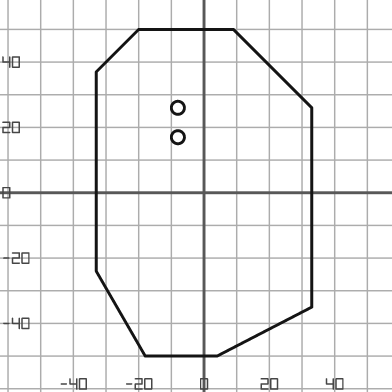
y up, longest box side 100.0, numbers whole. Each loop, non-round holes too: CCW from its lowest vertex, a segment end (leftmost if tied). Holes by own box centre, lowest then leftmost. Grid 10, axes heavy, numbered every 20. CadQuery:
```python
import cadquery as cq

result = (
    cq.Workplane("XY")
    .moveTo(-18.0, -50.0)
    .lineTo(4.0, -50.0)
    .lineTo(33.0, -35.0)
    .lineTo(33.0, 26.0)
    .lineTo(9.0, 50.0)
    .lineTo(-20.0, 50.0)
    .lineTo(-33.0, 37.0)
    .lineTo(-33.0, -24.0)
    .close()
    .moveTo(-8.0, 17.0)
    .circle(2.0)
    .moveTo(-8.0, 26.0)
    .circle(2.0)
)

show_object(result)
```